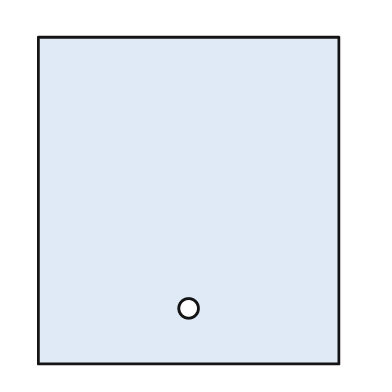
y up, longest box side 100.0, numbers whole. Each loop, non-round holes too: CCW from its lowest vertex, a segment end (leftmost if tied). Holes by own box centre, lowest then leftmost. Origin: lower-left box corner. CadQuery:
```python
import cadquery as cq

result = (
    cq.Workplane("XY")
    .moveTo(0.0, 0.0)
    .lineTo(92.0, 0.0)
    .lineTo(92.0, 100.0)
    .lineTo(0.0, 100.0)
    .close()
    .moveTo(46.0, 17.0)
    .circle(3.0)
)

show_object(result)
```